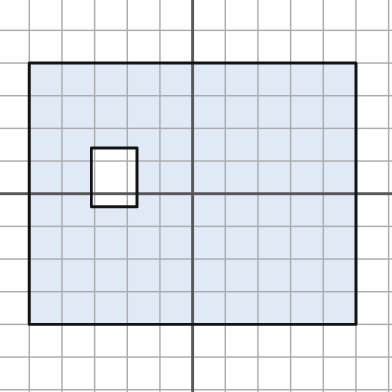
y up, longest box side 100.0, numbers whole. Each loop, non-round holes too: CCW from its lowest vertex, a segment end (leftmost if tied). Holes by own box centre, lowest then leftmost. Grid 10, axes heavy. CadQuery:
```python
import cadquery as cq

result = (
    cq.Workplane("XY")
    .moveTo(-50.0, -40.0)
    .lineTo(50.0, -40.0)
    .lineTo(50.0, 40.0)
    .lineTo(-50.0, 40.0)
    .close()
    .moveTo(-31.0, -4.0)
    .lineTo(-17.0, -4.0)
    .lineTo(-17.0, 14.0)
    .lineTo(-31.0, 14.0)
    .close()
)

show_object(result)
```